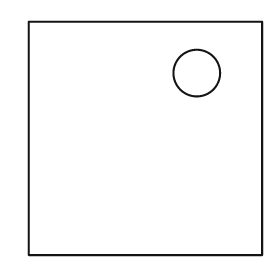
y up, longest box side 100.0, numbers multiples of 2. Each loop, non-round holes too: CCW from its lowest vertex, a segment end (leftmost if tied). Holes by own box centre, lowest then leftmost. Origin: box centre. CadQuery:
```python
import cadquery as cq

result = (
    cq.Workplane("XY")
    .moveTo(-50.0, -50.0)
    .lineTo(50.0, -50.0)
    .lineTo(50.0, 50.0)
    .lineTo(-50.0, 50.0)
    .close()
    .moveTo(22.0, 28.0)
    .circle(10.0)
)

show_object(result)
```